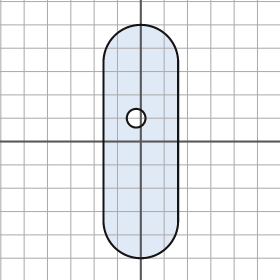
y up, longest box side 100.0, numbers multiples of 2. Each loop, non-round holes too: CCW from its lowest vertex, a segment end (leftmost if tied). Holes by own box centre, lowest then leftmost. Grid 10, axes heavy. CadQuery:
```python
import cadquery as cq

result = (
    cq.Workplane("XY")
    .moveTo(-16.0, -34.0)
    .threePointArc((0.0, -50.0), (16.0, -34.0))
    .lineTo(16.0, 34.0)
    .threePointArc((0.0, 50.0), (-16.0, 34.0))
    .close()
    .moveTo(-2.0, 10.0)
    .circle(4.0)
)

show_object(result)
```